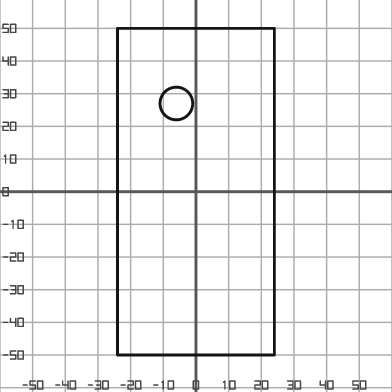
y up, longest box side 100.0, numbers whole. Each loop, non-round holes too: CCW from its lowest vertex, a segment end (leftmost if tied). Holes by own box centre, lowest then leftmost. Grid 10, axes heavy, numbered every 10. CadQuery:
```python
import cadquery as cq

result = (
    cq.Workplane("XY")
    .moveTo(-24.0, -50.0)
    .lineTo(24.0, -50.0)
    .lineTo(24.0, 50.0)
    .lineTo(-24.0, 50.0)
    .close()
    .moveTo(-6.0, 27.0)
    .circle(5.0)
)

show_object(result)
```